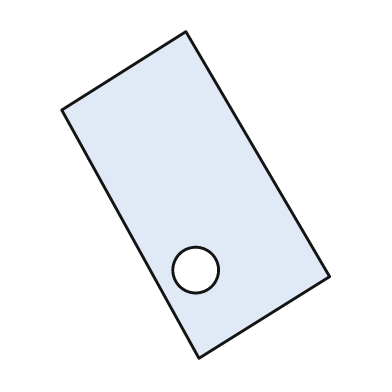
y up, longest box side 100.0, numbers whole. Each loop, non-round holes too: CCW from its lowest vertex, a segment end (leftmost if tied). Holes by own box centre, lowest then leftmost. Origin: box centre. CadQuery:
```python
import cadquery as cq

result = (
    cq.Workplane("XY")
    .moveTo(1.0, -50.0)
    .lineTo(41.0, -25.0)
    .lineTo(-3.0, 50.0)
    .lineTo(-41.0, 26.0)
    .close()
    .moveTo(0.0, -23.0)
    .circle(7.0)
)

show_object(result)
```